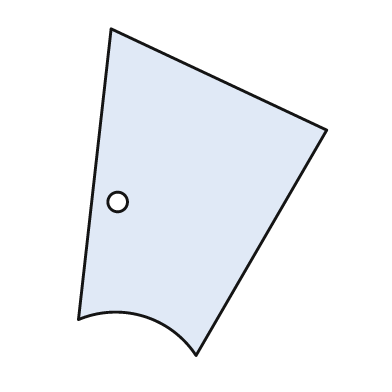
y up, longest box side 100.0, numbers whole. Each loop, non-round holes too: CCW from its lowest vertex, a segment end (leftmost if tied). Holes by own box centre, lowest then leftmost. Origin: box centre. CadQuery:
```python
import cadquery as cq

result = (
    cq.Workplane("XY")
    .moveTo(-2.0, -50.0)
    .lineTo(38.0, 19.0)
    .lineTo(-28.0, 50.0)
    .lineTo(-38.0, -39.0)
    .threePointArc((-18.0, -38.0), (-2.0, -50.0))
    .close()
    .moveTo(-26.0, -3.0)
    .circle(3.0)
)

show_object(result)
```